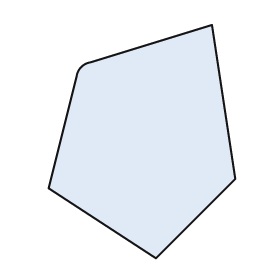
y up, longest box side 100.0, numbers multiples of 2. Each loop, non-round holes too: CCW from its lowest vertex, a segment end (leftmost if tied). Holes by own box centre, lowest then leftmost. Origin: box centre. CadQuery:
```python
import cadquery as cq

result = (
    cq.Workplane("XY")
    .moveTo(6.0, -50.0)
    .lineTo(40.0, -16.0)
    .lineTo(30.0, 50.0)
    .lineTo(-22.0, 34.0)
    .threePointArc((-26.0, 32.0), (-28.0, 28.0))
    .lineTo(-40.0, -20.0)
    .close()
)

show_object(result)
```